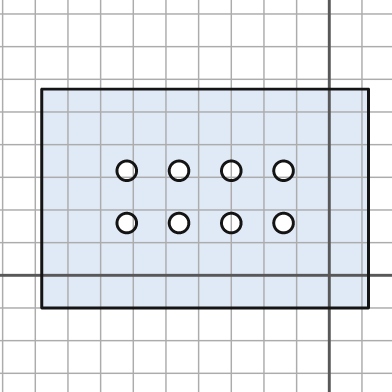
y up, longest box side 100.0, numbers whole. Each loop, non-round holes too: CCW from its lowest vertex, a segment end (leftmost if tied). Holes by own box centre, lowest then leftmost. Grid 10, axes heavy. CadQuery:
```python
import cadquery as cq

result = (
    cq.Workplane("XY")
    .moveTo(-88.0, -10.0)
    .lineTo(12.0, -10.0)
    .lineTo(12.0, 57.0)
    .lineTo(-88.0, 57.0)
    .close()
    .moveTo(-62.0, 16.0)
    .circle(3.0)
    .moveTo(-46.0, 16.0)
    .circle(3.0)
    .moveTo(-30.0, 16.0)
    .circle(3.0)
    .moveTo(-14.0, 16.0)
    .circle(3.0)
    .moveTo(-62.0, 32.0)
    .circle(3.0)
    .moveTo(-46.0, 32.0)
    .circle(3.0)
    .moveTo(-30.0, 32.0)
    .circle(3.0)
    .moveTo(-14.0, 32.0)
    .circle(3.0)
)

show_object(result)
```